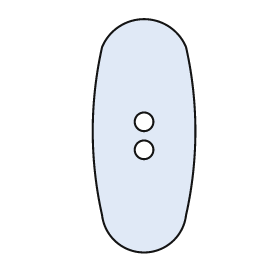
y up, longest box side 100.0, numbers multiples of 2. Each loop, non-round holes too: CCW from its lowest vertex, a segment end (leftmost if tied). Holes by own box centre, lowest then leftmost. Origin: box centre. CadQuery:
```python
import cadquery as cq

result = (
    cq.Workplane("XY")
    .moveTo(-18.0, -34.0)
    .threePointArc((0.0, -50.0), (18.0, -34.0))
    .threePointArc((22.0, 2.0), (18.0, 38.0))
    .threePointArc((0.0, 50.0), (-18.0, 38.0))
    .threePointArc((-22.0, 2.0), (-18.0, -34.0))
    .close()
    .moveTo(0.0, -6.0)
    .circle(4.0)
    .moveTo(0.0, 6.0)
    .circle(4.0)
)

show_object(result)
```